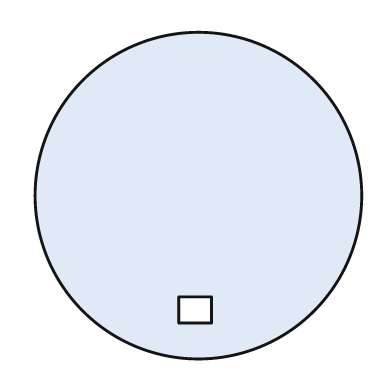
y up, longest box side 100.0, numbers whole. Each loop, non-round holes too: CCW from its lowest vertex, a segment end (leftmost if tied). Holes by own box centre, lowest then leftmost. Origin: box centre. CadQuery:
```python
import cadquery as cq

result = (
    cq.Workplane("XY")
    .moveTo(0.0, 0.0)
    .circle(50.0)
    .moveTo(-6.0, -39.0)
    .lineTo(4.0, -39.0)
    .lineTo(4.0, -31.0)
    .lineTo(-6.0, -31.0)
    .close()
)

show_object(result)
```